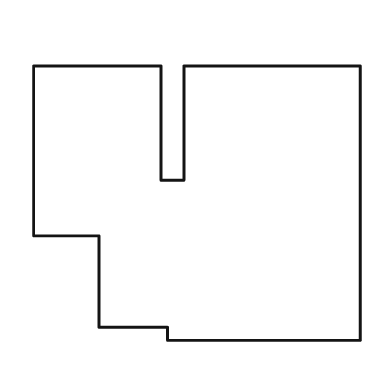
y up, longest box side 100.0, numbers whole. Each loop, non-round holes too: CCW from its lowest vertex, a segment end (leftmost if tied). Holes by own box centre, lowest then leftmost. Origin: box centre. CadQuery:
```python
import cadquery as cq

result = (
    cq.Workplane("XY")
    .moveTo(-9.0, -42.0)
    .lineTo(50.0, -42.0)
    .lineTo(50.0, 42.0)
    .lineTo(-4.0, 42.0)
    .lineTo(-4.0, 7.0)
    .lineTo(-11.0, 7.0)
    .lineTo(-11.0, 42.0)
    .lineTo(-50.0, 42.0)
    .lineTo(-50.0, -10.0)
    .lineTo(-30.0, -10.0)
    .lineTo(-30.0, -38.0)
    .lineTo(-9.0, -38.0)
    .close()
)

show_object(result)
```